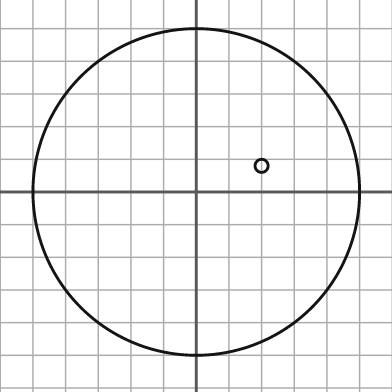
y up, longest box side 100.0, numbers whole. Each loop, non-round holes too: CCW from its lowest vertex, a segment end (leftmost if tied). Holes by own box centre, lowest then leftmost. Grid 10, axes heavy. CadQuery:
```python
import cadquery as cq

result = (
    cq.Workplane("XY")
    .moveTo(0.0, 0.0)
    .circle(50.0)
    .moveTo(20.0, 8.0)
    .circle(2.0)
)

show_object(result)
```